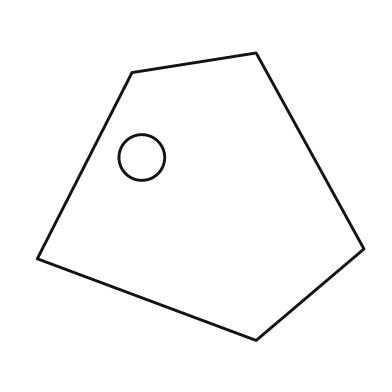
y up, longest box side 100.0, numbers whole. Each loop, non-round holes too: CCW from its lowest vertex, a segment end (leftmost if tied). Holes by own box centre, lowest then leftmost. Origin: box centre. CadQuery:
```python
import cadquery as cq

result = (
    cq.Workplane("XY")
    .moveTo(17.0, -44.0)
    .lineTo(50.0, -16.0)
    .lineTo(17.0, 44.0)
    .lineTo(-21.0, 38.0)
    .lineTo(-50.0, -19.0)
    .close()
    .moveTo(-18.0, 12.0)
    .circle(7.0)
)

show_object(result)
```